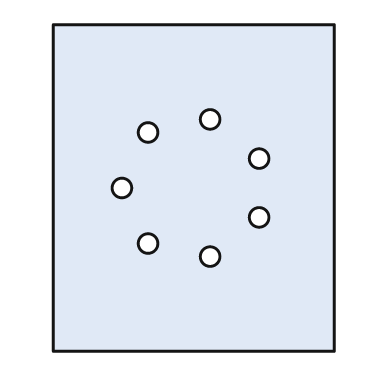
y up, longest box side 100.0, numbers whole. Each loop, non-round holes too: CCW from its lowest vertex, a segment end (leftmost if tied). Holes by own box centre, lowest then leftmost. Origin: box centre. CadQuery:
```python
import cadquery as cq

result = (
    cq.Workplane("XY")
    .moveTo(-43.0, -50.0)
    .lineTo(43.0, -50.0)
    .lineTo(43.0, 50.0)
    .lineTo(-43.0, 50.0)
    .close()
    .moveTo(5.0, -21.0)
    .circle(3.0)
    .moveTo(-14.0, -17.0)
    .circle(3.0)
    .moveTo(20.0, -9.0)
    .circle(3.0)
    .moveTo(-22.0, 0.0)
    .circle(3.0)
    .moveTo(20.0, 9.0)
    .circle(3.0)
    .moveTo(-14.0, 17.0)
    .circle(3.0)
    .moveTo(5.0, 21.0)
    .circle(3.0)
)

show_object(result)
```